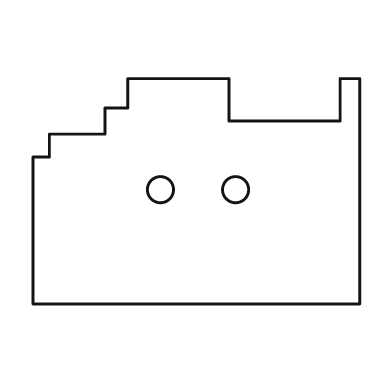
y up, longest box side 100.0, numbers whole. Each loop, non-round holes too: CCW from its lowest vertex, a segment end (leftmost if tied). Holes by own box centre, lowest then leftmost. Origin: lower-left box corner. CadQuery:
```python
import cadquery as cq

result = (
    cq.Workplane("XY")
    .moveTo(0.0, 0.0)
    .lineTo(100.0, 0.0)
    .lineTo(100.0, 69.0)
    .lineTo(94.0, 69.0)
    .lineTo(94.0, 56.0)
    .lineTo(60.0, 56.0)
    .lineTo(60.0, 69.0)
    .lineTo(29.0, 69.0)
    .lineTo(29.0, 60.0)
    .lineTo(22.0, 60.0)
    .lineTo(22.0, 52.0)
    .lineTo(5.0, 52.0)
    .lineTo(5.0, 45.0)
    .lineTo(0.0, 45.0)
    .close()
    .moveTo(39.0, 35.0)
    .circle(4.0)
    .moveTo(62.0, 35.0)
    .circle(4.0)
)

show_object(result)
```